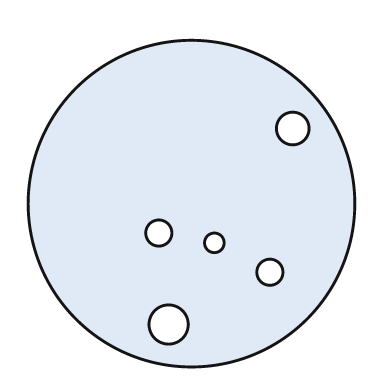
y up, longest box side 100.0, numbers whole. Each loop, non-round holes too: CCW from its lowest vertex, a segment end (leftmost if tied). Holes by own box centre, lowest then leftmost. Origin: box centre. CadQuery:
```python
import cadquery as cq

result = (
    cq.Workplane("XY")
    .moveTo(0.0, 0.0)
    .circle(50.0)
    .moveTo(-7.0, -37.0)
    .circle(6.0)
    .moveTo(24.0, -21.0)
    .circle(4.0)
    .moveTo(7.0, -12.0)
    .circle(3.0)
    .moveTo(-10.0, -9.0)
    .circle(4.0)
    .moveTo(31.0, 23.0)
    .circle(5.0)
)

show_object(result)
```